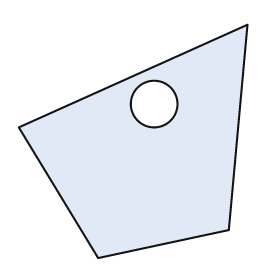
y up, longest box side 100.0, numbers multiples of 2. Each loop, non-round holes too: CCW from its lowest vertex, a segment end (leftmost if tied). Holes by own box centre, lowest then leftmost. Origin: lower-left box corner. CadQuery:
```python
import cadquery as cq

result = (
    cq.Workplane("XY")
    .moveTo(34.0, 0.0)
    .lineTo(90.0, 12.0)
    .lineTo(98.0, 100.0)
    .lineTo(0.0, 56.0)
    .close()
    .moveTo(58.0, 66.0)
    .circle(10.0)
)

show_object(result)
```